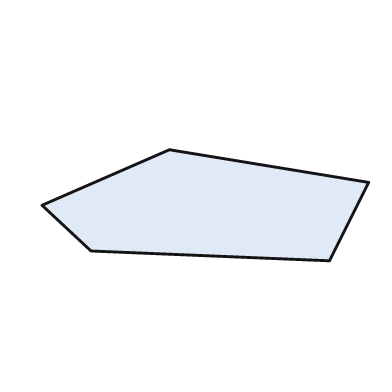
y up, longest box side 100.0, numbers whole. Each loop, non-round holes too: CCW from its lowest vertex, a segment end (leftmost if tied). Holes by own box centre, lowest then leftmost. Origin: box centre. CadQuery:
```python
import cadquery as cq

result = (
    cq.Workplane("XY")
    .moveTo(38.0, -17.0)
    .lineTo(50.0, 7.0)
    .lineTo(-11.0, 17.0)
    .lineTo(-50.0, 0.0)
    .lineTo(-35.0, -14.0)
    .close()
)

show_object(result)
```